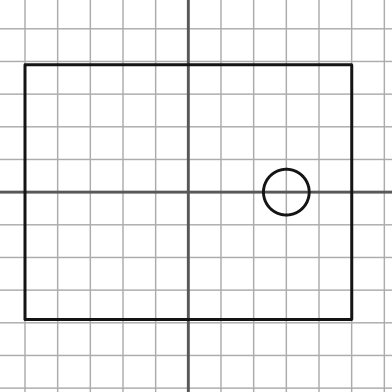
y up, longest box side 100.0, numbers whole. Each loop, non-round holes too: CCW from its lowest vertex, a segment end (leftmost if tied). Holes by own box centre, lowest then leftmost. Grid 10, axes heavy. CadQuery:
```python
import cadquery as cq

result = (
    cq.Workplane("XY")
    .moveTo(-50.0, -39.0)
    .lineTo(50.0, -39.0)
    .lineTo(50.0, 39.0)
    .lineTo(-50.0, 39.0)
    .close()
    .moveTo(30.0, 0.0)
    .circle(7.0)
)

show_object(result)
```